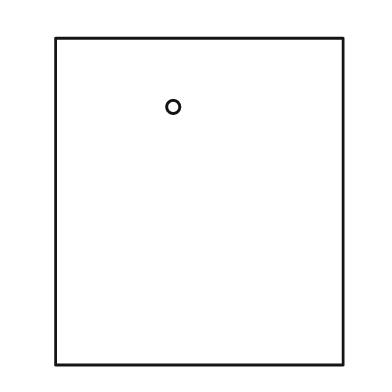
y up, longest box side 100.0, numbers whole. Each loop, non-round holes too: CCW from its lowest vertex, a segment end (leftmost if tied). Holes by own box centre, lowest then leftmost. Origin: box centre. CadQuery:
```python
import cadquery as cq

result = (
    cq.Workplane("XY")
    .moveTo(-44.0, -50.0)
    .lineTo(44.0, -50.0)
    .lineTo(44.0, 50.0)
    .lineTo(-44.0, 50.0)
    .close()
    .moveTo(-8.0, 29.0)
    .circle(2.0)
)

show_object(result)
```